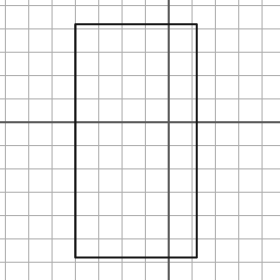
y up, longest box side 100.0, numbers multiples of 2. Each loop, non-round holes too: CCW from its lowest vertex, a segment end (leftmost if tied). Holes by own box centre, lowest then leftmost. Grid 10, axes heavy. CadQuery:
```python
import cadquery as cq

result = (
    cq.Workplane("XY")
    .moveTo(-40.0, -58.0)
    .lineTo(12.0, -58.0)
    .lineTo(12.0, 42.0)
    .lineTo(-40.0, 42.0)
    .close()
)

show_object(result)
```